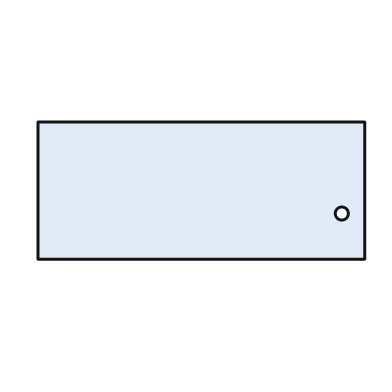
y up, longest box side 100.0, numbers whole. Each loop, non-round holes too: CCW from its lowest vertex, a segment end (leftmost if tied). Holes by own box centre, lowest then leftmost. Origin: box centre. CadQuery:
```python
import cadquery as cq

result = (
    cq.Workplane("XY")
    .moveTo(-50.0, -21.0)
    .lineTo(50.0, -21.0)
    .lineTo(50.0, 21.0)
    .lineTo(-50.0, 21.0)
    .close()
    .moveTo(43.0, -7.0)
    .circle(2.0)
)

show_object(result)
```